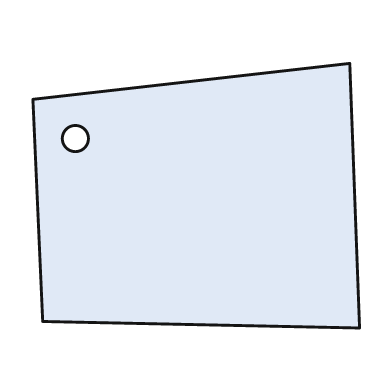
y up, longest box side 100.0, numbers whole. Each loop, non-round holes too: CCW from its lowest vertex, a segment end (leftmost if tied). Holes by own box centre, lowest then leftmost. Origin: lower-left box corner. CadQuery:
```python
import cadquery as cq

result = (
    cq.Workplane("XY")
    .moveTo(100.0, 0.0)
    .lineTo(97.0, 81.0)
    .lineTo(0.0, 70.0)
    .lineTo(3.0, 2.0)
    .close()
    .moveTo(13.0, 58.0)
    .circle(4.0)
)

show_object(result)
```